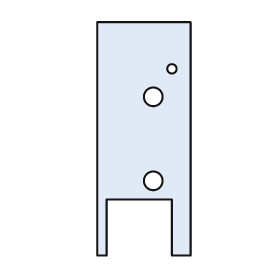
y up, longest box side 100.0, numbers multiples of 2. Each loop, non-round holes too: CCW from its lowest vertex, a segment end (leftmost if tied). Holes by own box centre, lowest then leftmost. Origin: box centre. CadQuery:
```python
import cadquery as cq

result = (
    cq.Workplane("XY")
    .moveTo(-20.0, -50.0)
    .lineTo(-16.0, -50.0)
    .lineTo(-16.0, -26.0)
    .lineTo(12.0, -26.0)
    .lineTo(12.0, -50.0)
    .lineTo(20.0, -50.0)
    .lineTo(20.0, 50.0)
    .lineTo(-20.0, 50.0)
    .close()
    .moveTo(4.0, -18.0)
    .circle(4.0)
    .moveTo(4.0, 18.0)
    .circle(4.0)
    .moveTo(12.0, 30.0)
    .circle(2.0)
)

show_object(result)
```